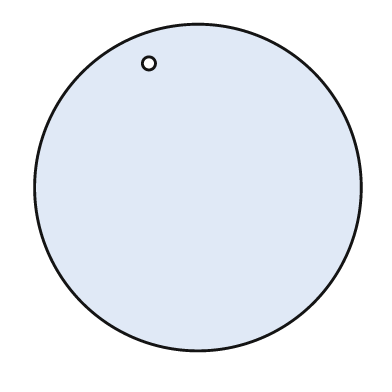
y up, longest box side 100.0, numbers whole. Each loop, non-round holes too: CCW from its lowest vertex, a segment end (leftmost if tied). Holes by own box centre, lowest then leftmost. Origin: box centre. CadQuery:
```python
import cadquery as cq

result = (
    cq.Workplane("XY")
    .moveTo(0.0, 0.0)
    .circle(50.0)
    .moveTo(-15.0, 38.0)
    .circle(2.0)
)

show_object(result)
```